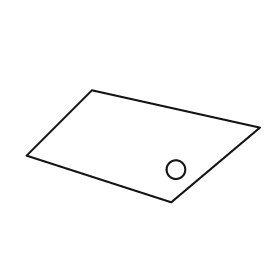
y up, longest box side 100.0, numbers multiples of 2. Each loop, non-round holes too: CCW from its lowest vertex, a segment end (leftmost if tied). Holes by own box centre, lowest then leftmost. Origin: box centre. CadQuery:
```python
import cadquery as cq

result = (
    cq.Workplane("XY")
    .moveTo(12.0, -24.0)
    .lineTo(50.0, 8.0)
    .lineTo(-22.0, 24.0)
    .lineTo(-50.0, -4.0)
    .close()
    .moveTo(14.0, -10.0)
    .circle(4.0)
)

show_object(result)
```